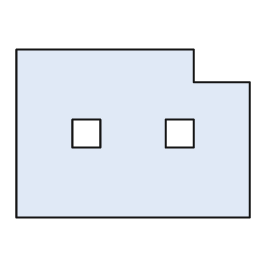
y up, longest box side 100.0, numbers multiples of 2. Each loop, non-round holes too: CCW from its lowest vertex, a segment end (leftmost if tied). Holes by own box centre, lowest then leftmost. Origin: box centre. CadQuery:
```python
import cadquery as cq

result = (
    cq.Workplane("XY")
    .moveTo(-50.0, -36.0)
    .lineTo(50.0, -36.0)
    .lineTo(50.0, 22.0)
    .lineTo(26.0, 22.0)
    .lineTo(26.0, 36.0)
    .lineTo(-50.0, 36.0)
    .close()
    .moveTo(-26.0, -6.0)
    .lineTo(-14.0, -6.0)
    .lineTo(-14.0, 6.0)
    .lineTo(-26.0, 6.0)
    .close()
    .moveTo(14.0, -6.0)
    .lineTo(26.0, -6.0)
    .lineTo(26.0, 6.0)
    .lineTo(14.0, 6.0)
    .close()
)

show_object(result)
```